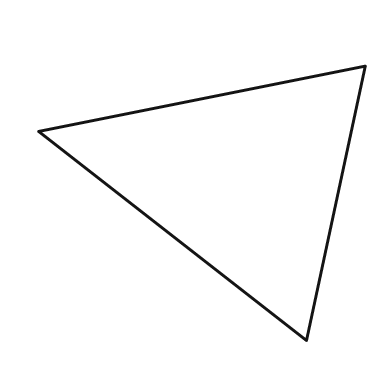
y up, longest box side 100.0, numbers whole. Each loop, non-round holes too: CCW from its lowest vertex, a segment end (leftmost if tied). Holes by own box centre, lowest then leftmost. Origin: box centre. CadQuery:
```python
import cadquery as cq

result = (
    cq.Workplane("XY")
    .moveTo(32.0, -42.0)
    .lineTo(50.0, 42.0)
    .lineTo(-50.0, 22.0)
    .close()
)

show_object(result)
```